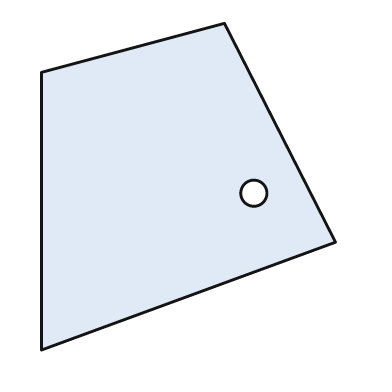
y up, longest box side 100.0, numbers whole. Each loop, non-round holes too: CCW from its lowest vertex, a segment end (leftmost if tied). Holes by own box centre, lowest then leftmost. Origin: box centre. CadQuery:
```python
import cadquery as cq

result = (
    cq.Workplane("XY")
    .moveTo(-45.0, -50.0)
    .lineTo(45.0, -17.0)
    .lineTo(11.0, 50.0)
    .lineTo(-45.0, 35.0)
    .close()
    .moveTo(20.0, -2.0)
    .circle(4.0)
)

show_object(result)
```